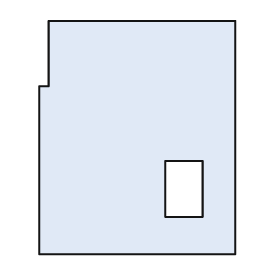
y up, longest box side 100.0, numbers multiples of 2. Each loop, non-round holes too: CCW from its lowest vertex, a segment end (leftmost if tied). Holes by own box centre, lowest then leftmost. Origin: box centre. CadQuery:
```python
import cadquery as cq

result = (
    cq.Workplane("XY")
    .moveTo(-42.0, -50.0)
    .lineTo(42.0, -50.0)
    .lineTo(42.0, 50.0)
    .lineTo(-38.0, 50.0)
    .lineTo(-38.0, 22.0)
    .lineTo(-42.0, 22.0)
    .close()
    .moveTo(12.0, -34.0)
    .lineTo(28.0, -34.0)
    .lineTo(28.0, -10.0)
    .lineTo(12.0, -10.0)
    .close()
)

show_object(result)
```